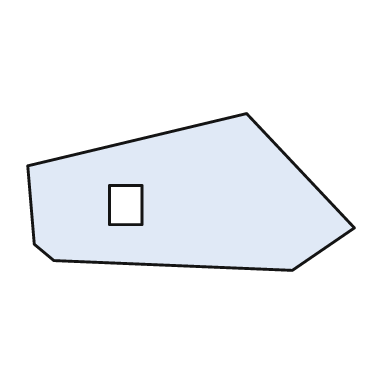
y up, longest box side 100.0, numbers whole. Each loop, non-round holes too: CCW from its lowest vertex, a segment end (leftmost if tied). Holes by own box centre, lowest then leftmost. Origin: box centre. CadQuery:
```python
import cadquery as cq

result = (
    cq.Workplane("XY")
    .moveTo(31.0, -24.0)
    .lineTo(50.0, -11.0)
    .lineTo(17.0, 24.0)
    .lineTo(-50.0, 8.0)
    .lineTo(-48.0, -16.0)
    .lineTo(-42.0, -21.0)
    .close()
    .moveTo(-25.0, -10.0)
    .lineTo(-15.0, -10.0)
    .lineTo(-15.0, 2.0)
    .lineTo(-25.0, 2.0)
    .close()
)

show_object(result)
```